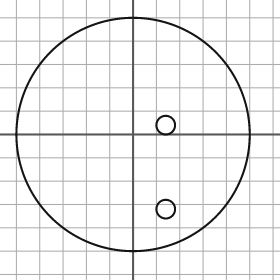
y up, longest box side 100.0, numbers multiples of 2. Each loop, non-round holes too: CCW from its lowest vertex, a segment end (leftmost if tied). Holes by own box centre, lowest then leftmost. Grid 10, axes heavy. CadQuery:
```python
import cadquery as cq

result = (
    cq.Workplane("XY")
    .moveTo(0.0, 0.0)
    .circle(50.0)
    .moveTo(14.0, -32.0)
    .circle(4.0)
    .moveTo(14.0, 4.0)
    .circle(4.0)
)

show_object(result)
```